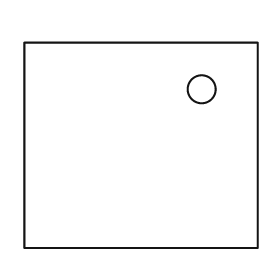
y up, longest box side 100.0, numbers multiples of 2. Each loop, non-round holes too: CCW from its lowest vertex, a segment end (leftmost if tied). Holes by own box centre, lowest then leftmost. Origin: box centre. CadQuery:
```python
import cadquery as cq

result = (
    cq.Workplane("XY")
    .moveTo(-50.0, -44.0)
    .lineTo(50.0, -44.0)
    .lineTo(50.0, 44.0)
    .lineTo(-50.0, 44.0)
    .close()
    .moveTo(26.0, 24.0)
    .circle(6.0)
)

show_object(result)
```